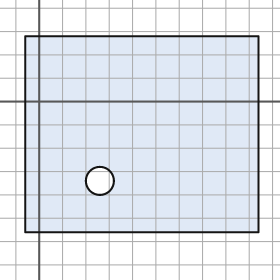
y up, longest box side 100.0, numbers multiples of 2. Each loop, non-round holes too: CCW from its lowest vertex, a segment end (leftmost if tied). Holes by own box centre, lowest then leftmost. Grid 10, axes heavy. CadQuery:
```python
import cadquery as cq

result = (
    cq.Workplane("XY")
    .moveTo(-6.0, -56.0)
    .lineTo(94.0, -56.0)
    .lineTo(94.0, 28.0)
    .lineTo(-6.0, 28.0)
    .close()
    .moveTo(26.0, -34.0)
    .circle(6.0)
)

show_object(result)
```